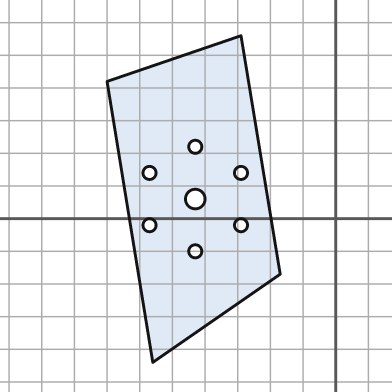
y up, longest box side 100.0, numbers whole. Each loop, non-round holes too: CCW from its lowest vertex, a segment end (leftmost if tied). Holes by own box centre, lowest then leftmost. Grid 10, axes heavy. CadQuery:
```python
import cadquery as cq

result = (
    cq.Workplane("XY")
    .moveTo(-56.0, -44.0)
    .lineTo(-17.0, -17.0)
    .lineTo(-29.0, 56.0)
    .lineTo(-70.0, 42.0)
    .close()
    .moveTo(-43.0, -10.0)
    .circle(2.0)
    .moveTo(-57.0, -2.0)
    .circle(2.0)
    .moveTo(-29.0, -2.0)
    .circle(2.0)
    .moveTo(-43.0, 6.0)
    .circle(3.0)
    .moveTo(-57.0, 14.0)
    .circle(2.0)
    .moveTo(-29.0, 14.0)
    .circle(2.0)
    .moveTo(-43.0, 22.0)
    .circle(2.0)
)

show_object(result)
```